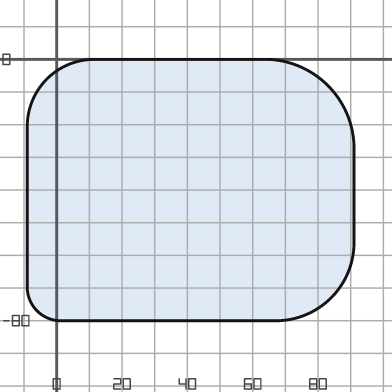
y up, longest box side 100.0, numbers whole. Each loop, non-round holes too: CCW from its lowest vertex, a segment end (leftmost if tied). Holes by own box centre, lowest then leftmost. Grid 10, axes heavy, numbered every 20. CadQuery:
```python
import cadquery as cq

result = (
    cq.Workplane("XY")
    .moveTo(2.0, -80.0)
    .lineTo(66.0, -80.0)
    .threePointArc((84.0, -73.0), (91.0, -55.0))
    .lineTo(91.0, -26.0)
    .threePointArc((83.0, -8.0), (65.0, 0.0))
    .lineTo(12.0, 0.0)
    .threePointArc((-3.0, -6.0), (-9.0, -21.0))
    .lineTo(-9.0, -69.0)
    .threePointArc((-6.0, -77.0), (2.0, -80.0))
    .close()
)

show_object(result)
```